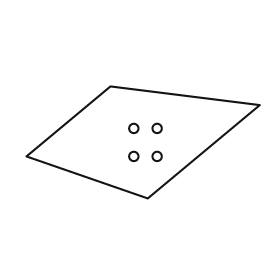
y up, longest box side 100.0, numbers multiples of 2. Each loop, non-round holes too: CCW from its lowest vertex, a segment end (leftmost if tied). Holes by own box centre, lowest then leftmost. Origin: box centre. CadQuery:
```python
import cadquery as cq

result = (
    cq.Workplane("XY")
    .moveTo(2.0, -24.0)
    .lineTo(50.0, 16.0)
    .lineTo(-14.0, 24.0)
    .lineTo(-50.0, -6.0)
    .close()
    .moveTo(-4.0, -6.0)
    .circle(2.0)
    .moveTo(6.0, -6.0)
    .circle(2.0)
    .moveTo(-4.0, 6.0)
    .circle(2.0)
    .moveTo(6.0, 6.0)
    .circle(2.0)
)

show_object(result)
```